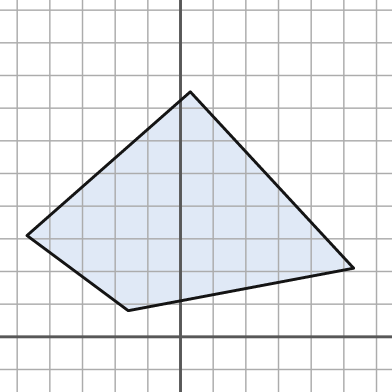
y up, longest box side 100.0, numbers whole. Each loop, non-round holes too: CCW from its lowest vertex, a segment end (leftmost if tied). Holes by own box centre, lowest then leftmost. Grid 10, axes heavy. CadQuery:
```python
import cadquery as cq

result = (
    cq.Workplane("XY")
    .moveTo(-16.0, 8.0)
    .lineTo(53.0, 21.0)
    .lineTo(3.0, 75.0)
    .lineTo(-47.0, 31.0)
    .close()
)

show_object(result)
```